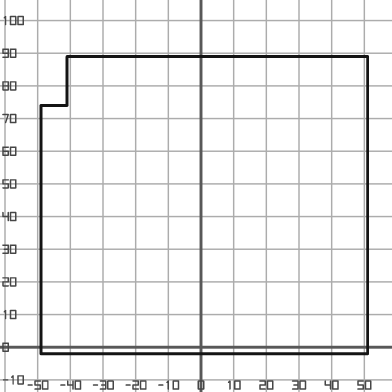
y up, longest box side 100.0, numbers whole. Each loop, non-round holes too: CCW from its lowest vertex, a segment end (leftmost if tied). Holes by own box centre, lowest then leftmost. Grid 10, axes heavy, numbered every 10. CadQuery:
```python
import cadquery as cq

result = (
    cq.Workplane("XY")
    .moveTo(-49.0, -2.0)
    .lineTo(51.0, -2.0)
    .lineTo(51.0, 89.0)
    .lineTo(-41.0, 89.0)
    .lineTo(-41.0, 74.0)
    .lineTo(-49.0, 74.0)
    .close()
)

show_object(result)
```